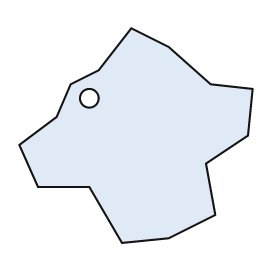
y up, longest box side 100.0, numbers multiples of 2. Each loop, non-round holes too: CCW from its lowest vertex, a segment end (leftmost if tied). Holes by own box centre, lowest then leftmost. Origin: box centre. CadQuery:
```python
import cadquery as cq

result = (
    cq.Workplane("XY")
    .moveTo(-6.0, -46.0)
    .lineTo(14.0, -44.0)
    .lineTo(34.0, -34.0)
    .lineTo(30.0, -12.0)
    .lineTo(48.0, 0.0)
    .lineTo(50.0, 20.0)
    .lineTo(32.0, 22.0)
    .lineTo(14.0, 38.0)
    .lineTo(-2.0, 46.0)
    .lineTo(-16.0, 28.0)
    .lineTo(-28.0, 22.0)
    .lineTo(-34.0, 8.0)
    .lineTo(-50.0, -4.0)
    .lineTo(-42.0, -22.0)
    .lineTo(-20.0, -22.0)
    .close()
    .moveTo(-20.0, 16.0)
    .circle(4.0)
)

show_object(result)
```